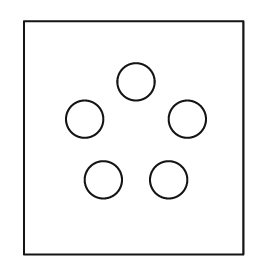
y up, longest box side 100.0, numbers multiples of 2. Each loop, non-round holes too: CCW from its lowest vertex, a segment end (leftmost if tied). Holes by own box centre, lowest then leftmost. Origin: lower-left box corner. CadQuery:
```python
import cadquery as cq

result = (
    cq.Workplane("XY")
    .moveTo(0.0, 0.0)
    .lineTo(94.0, 0.0)
    .lineTo(94.0, 100.0)
    .lineTo(0.0, 100.0)
    .close()
    .moveTo(34.0, 32.0)
    .circle(8.0)
    .moveTo(62.0, 32.0)
    .circle(8.0)
    .moveTo(26.0, 58.0)
    .circle(8.0)
    .moveTo(70.0, 58.0)
    .circle(8.0)
    .moveTo(48.0, 74.0)
    .circle(8.0)
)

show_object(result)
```